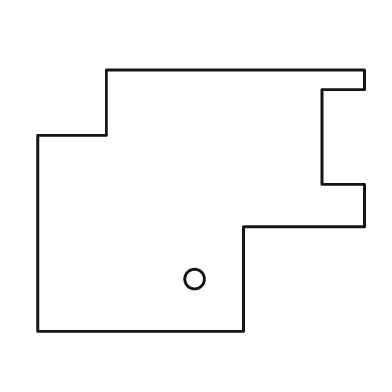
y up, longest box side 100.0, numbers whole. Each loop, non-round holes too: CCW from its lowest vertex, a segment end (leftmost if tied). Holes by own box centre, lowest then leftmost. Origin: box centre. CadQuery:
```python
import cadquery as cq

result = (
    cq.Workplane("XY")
    .moveTo(-50.0, -40.0)
    .lineTo(13.0, -40.0)
    .lineTo(13.0, -8.0)
    .lineTo(50.0, -8.0)
    .lineTo(50.0, 5.0)
    .lineTo(37.0, 5.0)
    .lineTo(37.0, 34.0)
    .lineTo(50.0, 34.0)
    .lineTo(50.0, 40.0)
    .lineTo(-29.0, 40.0)
    .lineTo(-29.0, 20.0)
    .lineTo(-50.0, 20.0)
    .close()
    .moveTo(-2.0, -24.0)
    .circle(3.0)
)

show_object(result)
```